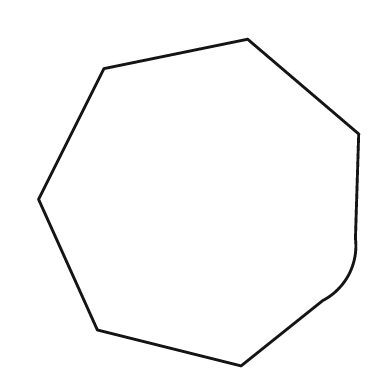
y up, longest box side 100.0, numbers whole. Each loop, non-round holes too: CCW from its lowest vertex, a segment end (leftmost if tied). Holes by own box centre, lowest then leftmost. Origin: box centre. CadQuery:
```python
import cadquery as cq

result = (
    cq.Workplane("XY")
    .moveTo(13.0, -50.0)
    .lineTo(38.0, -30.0)
    .threePointArc((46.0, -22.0), (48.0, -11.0))
    .lineTo(49.0, 21.0)
    .lineTo(15.0, 50.0)
    .lineTo(-29.0, 41.0)
    .lineTo(-49.0, 1.0)
    .lineTo(-31.0, -39.0)
    .close()
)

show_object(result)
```